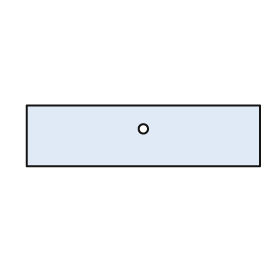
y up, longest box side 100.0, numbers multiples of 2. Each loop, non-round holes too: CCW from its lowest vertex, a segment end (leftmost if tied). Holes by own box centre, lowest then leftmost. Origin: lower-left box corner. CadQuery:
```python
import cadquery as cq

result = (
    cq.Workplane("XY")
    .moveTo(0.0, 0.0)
    .lineTo(100.0, 0.0)
    .lineTo(100.0, 26.0)
    .lineTo(0.0, 26.0)
    .close()
    .moveTo(50.0, 16.0)
    .circle(2.0)
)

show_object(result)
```